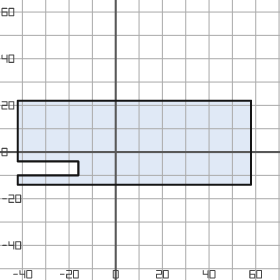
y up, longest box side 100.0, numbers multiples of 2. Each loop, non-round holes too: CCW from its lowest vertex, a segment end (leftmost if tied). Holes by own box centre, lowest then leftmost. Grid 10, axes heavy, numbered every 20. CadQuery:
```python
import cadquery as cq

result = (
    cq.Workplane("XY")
    .moveTo(-42.0, -14.0)
    .lineTo(58.0, -14.0)
    .lineTo(58.0, 22.0)
    .lineTo(-42.0, 22.0)
    .lineTo(-42.0, -4.0)
    .lineTo(-16.0, -4.0)
    .lineTo(-16.0, -10.0)
    .lineTo(-42.0, -10.0)
    .close()
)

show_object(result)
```